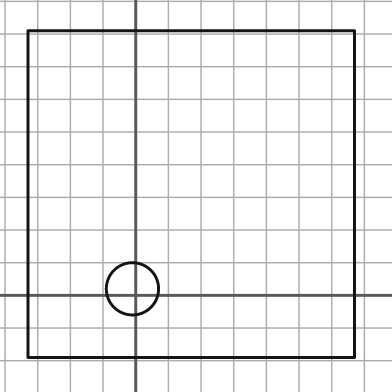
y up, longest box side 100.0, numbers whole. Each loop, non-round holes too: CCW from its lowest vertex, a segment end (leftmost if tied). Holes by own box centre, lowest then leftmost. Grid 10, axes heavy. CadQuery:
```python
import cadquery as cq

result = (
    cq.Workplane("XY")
    .moveTo(-33.0, -19.0)
    .lineTo(67.0, -19.0)
    .lineTo(67.0, 81.0)
    .lineTo(-33.0, 81.0)
    .close()
    .moveTo(-1.0, 2.0)
    .circle(8.0)
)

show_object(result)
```